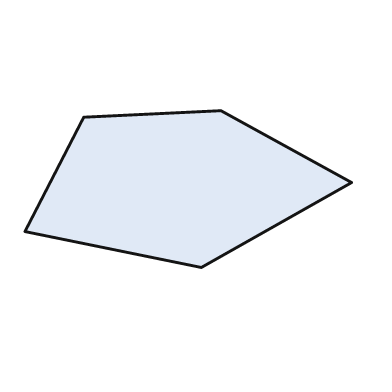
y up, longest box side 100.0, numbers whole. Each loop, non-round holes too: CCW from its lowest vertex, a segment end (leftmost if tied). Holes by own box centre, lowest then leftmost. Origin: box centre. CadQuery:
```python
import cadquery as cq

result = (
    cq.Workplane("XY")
    .moveTo(4.0, -24.0)
    .lineTo(50.0, 2.0)
    .lineTo(10.0, 24.0)
    .lineTo(-32.0, 22.0)
    .lineTo(-50.0, -13.0)
    .close()
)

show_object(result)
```